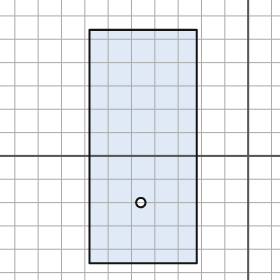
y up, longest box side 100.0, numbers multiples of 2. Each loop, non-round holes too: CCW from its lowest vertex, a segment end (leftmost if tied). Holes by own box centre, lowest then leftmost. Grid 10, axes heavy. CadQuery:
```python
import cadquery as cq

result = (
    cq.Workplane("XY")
    .moveTo(-68.0, -46.0)
    .lineTo(-22.0, -46.0)
    .lineTo(-22.0, 54.0)
    .lineTo(-68.0, 54.0)
    .close()
    .moveTo(-46.0, -20.0)
    .circle(2.0)
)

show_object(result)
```